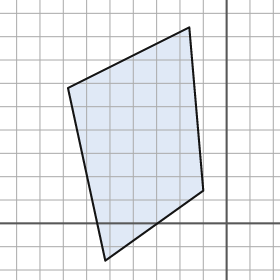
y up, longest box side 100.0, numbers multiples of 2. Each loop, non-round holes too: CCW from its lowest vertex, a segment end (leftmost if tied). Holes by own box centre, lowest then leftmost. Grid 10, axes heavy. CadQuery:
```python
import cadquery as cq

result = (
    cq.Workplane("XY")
    .moveTo(-52.0, -16.0)
    .lineTo(-10.0, 14.0)
    .lineTo(-16.0, 84.0)
    .lineTo(-68.0, 58.0)
    .close()
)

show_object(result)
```